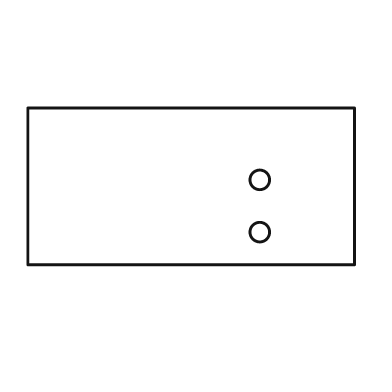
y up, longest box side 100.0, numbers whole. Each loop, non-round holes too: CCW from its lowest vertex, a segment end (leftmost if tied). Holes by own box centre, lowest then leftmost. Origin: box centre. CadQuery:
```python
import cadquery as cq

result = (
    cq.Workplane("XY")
    .moveTo(-50.0, -24.0)
    .lineTo(50.0, -24.0)
    .lineTo(50.0, 24.0)
    .lineTo(-50.0, 24.0)
    .close()
    .moveTo(21.0, -14.0)
    .circle(3.0)
    .moveTo(21.0, 2.0)
    .circle(3.0)
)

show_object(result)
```